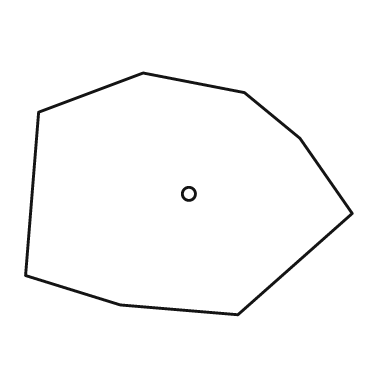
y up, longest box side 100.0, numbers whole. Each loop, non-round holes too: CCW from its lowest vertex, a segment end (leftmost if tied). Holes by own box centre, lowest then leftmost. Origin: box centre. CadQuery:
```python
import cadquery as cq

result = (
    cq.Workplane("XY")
    .moveTo(15.0, -37.0)
    .lineTo(50.0, -6.0)
    .lineTo(34.0, 17.0)
    .lineTo(17.0, 31.0)
    .lineTo(-14.0, 37.0)
    .lineTo(-46.0, 25.0)
    .lineTo(-50.0, -25.0)
    .lineTo(-21.0, -34.0)
    .close()
    .moveTo(0.0, 0.0)
    .circle(2.0)
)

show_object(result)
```